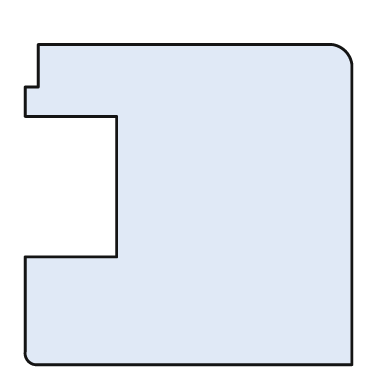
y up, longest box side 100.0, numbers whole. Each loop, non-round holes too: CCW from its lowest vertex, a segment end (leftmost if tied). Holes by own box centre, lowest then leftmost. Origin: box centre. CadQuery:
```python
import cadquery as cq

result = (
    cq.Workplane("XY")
    .moveTo(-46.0, -49.0)
    .lineTo(50.0, -49.0)
    .lineTo(50.0, 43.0)
    .threePointArc((48.0, 47.0), (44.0, 49.0))
    .lineTo(-46.0, 49.0)
    .lineTo(-46.0, 36.0)
    .lineTo(-50.0, 36.0)
    .lineTo(-50.0, 27.0)
    .lineTo(-22.0, 27.0)
    .lineTo(-22.0, -16.0)
    .lineTo(-50.0, -16.0)
    .lineTo(-50.0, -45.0)
    .threePointArc((-49.0, -48.0), (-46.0, -49.0))
    .close()
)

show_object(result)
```